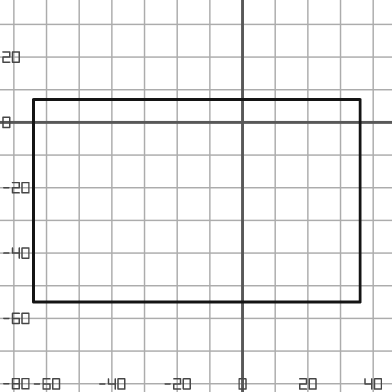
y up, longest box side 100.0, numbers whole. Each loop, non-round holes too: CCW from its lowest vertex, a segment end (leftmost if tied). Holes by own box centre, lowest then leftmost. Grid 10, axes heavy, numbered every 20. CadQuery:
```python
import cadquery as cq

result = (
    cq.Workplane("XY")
    .moveTo(-64.0, -55.0)
    .lineTo(36.0, -55.0)
    .lineTo(36.0, 7.0)
    .lineTo(-64.0, 7.0)
    .close()
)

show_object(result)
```